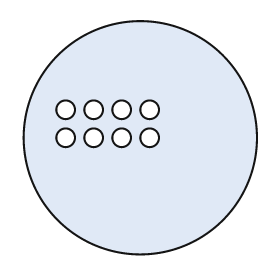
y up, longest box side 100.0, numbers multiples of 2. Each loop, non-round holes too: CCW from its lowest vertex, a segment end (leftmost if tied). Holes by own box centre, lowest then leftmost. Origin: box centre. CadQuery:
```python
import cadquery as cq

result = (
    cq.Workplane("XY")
    .moveTo(0.0, 0.0)
    .circle(50.0)
    .moveTo(-32.0, 0.0)
    .circle(4.0)
    .moveTo(-20.0, 0.0)
    .circle(4.0)
    .moveTo(-8.0, 0.0)
    .circle(4.0)
    .moveTo(4.0, 0.0)
    .circle(4.0)
    .moveTo(-32.0, 12.0)
    .circle(4.0)
    .moveTo(-20.0, 12.0)
    .circle(4.0)
    .moveTo(-8.0, 12.0)
    .circle(4.0)
    .moveTo(4.0, 12.0)
    .circle(4.0)
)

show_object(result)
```